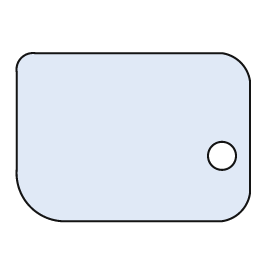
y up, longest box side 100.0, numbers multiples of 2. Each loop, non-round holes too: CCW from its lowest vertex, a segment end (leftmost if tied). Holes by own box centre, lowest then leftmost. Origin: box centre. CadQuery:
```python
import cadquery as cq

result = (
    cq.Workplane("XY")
    .moveTo(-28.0, -36.0)
    .lineTo(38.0, -36.0)
    .threePointArc((46.0, -32.0), (50.0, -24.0))
    .lineTo(50.0, 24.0)
    .threePointArc((46.0, 32.0), (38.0, 36.0))
    .lineTo(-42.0, 36.0)
    .threePointArc((-48.0, 34.0), (-50.0, 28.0))
    .lineTo(-50.0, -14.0)
    .threePointArc((-44.0, -30.0), (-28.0, -36.0))
    .close()
    .moveTo(38.0, -8.0)
    .circle(6.0)
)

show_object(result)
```